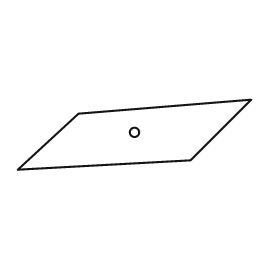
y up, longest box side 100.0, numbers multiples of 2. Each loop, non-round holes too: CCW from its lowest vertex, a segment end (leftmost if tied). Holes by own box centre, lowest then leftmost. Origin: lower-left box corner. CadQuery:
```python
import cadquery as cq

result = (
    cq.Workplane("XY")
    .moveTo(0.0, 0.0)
    .lineTo(74.0, 4.0)
    .lineTo(100.0, 30.0)
    .lineTo(26.0, 24.0)
    .close()
    .moveTo(50.0, 16.0)
    .circle(2.0)
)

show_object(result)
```